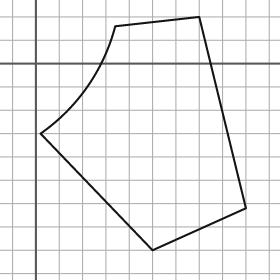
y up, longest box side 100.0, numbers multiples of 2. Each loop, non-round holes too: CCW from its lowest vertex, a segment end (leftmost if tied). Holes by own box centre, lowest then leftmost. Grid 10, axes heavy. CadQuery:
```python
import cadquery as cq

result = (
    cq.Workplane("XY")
    .moveTo(50.0, -80.0)
    .lineTo(90.0, -62.0)
    .lineTo(70.0, 20.0)
    .lineTo(34.0, 16.0)
    .threePointArc((22.0, -10.0), (2.0, -30.0))
    .close()
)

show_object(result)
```